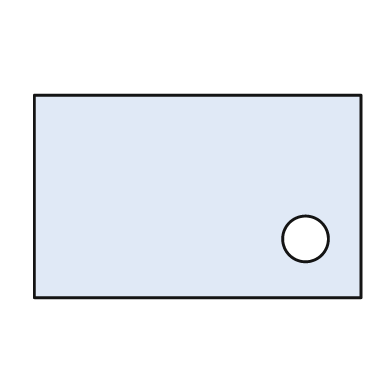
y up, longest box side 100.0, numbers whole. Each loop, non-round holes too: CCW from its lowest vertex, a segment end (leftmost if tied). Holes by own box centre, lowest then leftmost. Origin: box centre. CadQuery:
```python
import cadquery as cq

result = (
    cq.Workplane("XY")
    .moveTo(-50.0, -31.0)
    .lineTo(50.0, -31.0)
    .lineTo(50.0, 31.0)
    .lineTo(-50.0, 31.0)
    .close()
    .moveTo(33.0, -13.0)
    .circle(7.0)
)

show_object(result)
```